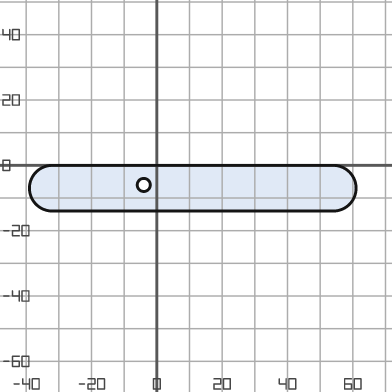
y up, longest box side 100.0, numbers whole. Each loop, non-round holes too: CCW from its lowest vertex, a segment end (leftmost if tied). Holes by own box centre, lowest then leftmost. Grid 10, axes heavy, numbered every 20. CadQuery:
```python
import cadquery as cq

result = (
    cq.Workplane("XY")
    .moveTo(-32.0, -14.0)
    .lineTo(54.0, -14.0)
    .threePointArc((61.0, -7.0), (54.0, 0.0))
    .lineTo(-32.0, 0.0)
    .threePointArc((-39.0, -7.0), (-32.0, -14.0))
    .close()
    .moveTo(-4.0, -6.0)
    .circle(2.0)
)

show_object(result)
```